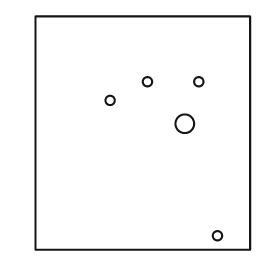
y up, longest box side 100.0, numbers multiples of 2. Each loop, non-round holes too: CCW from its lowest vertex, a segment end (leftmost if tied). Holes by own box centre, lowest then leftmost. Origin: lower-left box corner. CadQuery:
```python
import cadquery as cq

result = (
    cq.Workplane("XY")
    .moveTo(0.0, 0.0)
    .lineTo(92.0, 0.0)
    .lineTo(92.0, 100.0)
    .lineTo(0.0, 100.0)
    .close()
    .moveTo(78.0, 6.0)
    .circle(2.0)
    .moveTo(64.0, 54.0)
    .circle(4.0)
    .moveTo(32.0, 64.0)
    .circle(2.0)
    .moveTo(48.0, 72.0)
    .circle(2.0)
    .moveTo(70.0, 72.0)
    .circle(2.0)
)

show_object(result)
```